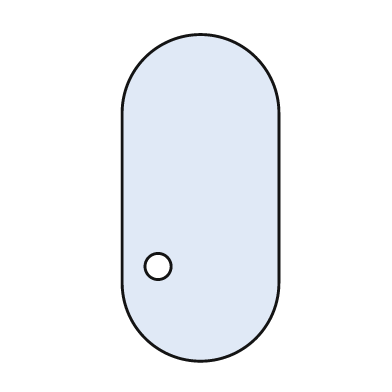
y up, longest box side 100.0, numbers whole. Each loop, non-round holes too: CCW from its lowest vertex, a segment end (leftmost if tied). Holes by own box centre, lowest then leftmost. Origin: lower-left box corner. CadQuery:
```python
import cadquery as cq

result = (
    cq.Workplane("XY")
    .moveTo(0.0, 24.0)
    .threePointArc((24.0, 0.0), (48.0, 24.0))
    .lineTo(48.0, 76.0)
    .threePointArc((24.0, 100.0), (0.0, 76.0))
    .close()
    .moveTo(11.0, 29.0)
    .circle(4.0)
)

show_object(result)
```